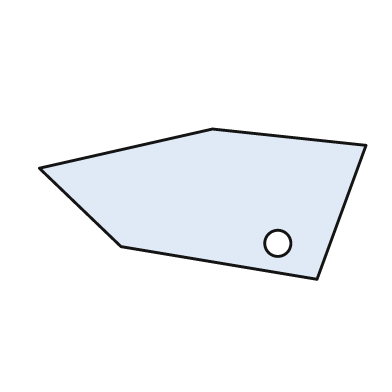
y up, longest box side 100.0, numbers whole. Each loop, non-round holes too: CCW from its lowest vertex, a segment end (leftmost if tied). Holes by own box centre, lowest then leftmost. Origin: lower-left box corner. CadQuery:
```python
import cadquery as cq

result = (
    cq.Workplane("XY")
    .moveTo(85.0, 0.0)
    .lineTo(100.0, 41.0)
    .lineTo(53.0, 46.0)
    .lineTo(0.0, 34.0)
    .lineTo(25.0, 10.0)
    .close()
    .moveTo(73.0, 11.0)
    .circle(4.0)
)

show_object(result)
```